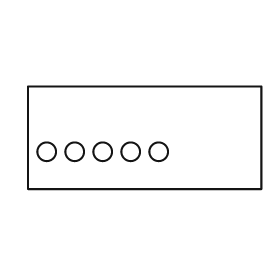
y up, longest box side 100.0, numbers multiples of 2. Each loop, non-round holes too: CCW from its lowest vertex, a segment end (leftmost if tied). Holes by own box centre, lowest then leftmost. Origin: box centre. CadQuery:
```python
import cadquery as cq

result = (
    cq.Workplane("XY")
    .moveTo(-50.0, -22.0)
    .lineTo(50.0, -22.0)
    .lineTo(50.0, 22.0)
    .lineTo(-50.0, 22.0)
    .close()
    .moveTo(-42.0, -6.0)
    .circle(4.0)
    .moveTo(-30.0, -6.0)
    .circle(4.0)
    .moveTo(-18.0, -6.0)
    .circle(4.0)
    .moveTo(-6.0, -6.0)
    .circle(4.0)
    .moveTo(6.0, -6.0)
    .circle(4.0)
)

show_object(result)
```